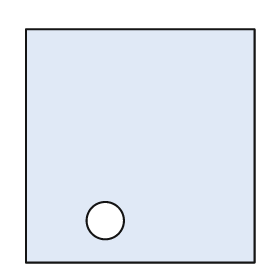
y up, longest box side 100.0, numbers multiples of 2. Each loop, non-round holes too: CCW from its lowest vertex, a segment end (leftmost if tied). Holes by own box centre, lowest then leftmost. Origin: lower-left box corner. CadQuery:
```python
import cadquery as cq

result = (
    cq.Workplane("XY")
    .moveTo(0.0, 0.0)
    .lineTo(98.0, 0.0)
    .lineTo(98.0, 100.0)
    .lineTo(0.0, 100.0)
    .close()
    .moveTo(34.0, 18.0)
    .circle(8.0)
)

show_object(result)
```